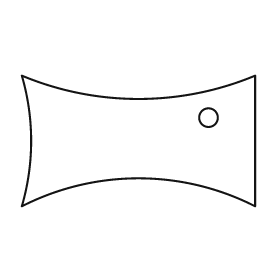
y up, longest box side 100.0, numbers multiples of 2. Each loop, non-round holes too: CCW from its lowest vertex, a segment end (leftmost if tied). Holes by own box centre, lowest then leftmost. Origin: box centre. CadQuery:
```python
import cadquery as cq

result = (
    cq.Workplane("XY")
    .moveTo(-50.0, -28.0)
    .threePointArc((0.0, -16.0), (50.0, -28.0))
    .lineTo(50.0, 28.0)
    .threePointArc((0.0, 18.0), (-50.0, 28.0))
    .threePointArc((-46.0, 0.0), (-50.0, -28.0))
    .close()
    .moveTo(30.0, 10.0)
    .circle(4.0)
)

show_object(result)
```